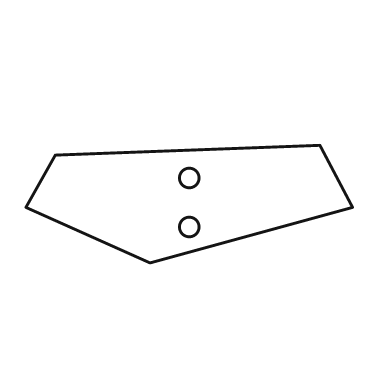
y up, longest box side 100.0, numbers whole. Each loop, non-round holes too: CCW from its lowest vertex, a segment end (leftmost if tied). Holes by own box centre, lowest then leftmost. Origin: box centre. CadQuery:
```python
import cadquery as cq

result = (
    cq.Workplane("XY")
    .moveTo(-12.0, -18.0)
    .lineTo(50.0, -1.0)
    .lineTo(40.0, 18.0)
    .lineTo(-41.0, 15.0)
    .lineTo(-50.0, -1.0)
    .close()
    .moveTo(0.0, -7.0)
    .circle(3.0)
    .moveTo(0.0, 8.0)
    .circle(3.0)
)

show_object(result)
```